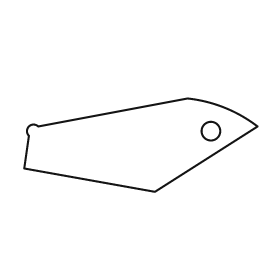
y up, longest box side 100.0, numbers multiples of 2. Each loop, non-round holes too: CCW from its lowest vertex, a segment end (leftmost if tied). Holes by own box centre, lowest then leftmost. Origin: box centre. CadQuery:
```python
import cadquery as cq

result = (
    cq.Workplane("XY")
    .moveTo(6.0, -20.0)
    .lineTo(50.0, 8.0)
    .threePointArc((36.0, 16.0), (20.0, 20.0))
    .lineTo(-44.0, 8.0)
    .threePointArc((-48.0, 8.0), (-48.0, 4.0))
    .lineTo(-50.0, -10.0)
    .close()
    .moveTo(30.0, 6.0)
    .circle(4.0)
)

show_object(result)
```